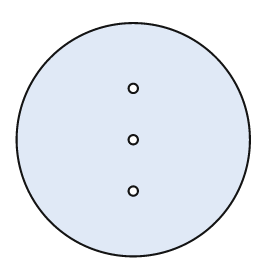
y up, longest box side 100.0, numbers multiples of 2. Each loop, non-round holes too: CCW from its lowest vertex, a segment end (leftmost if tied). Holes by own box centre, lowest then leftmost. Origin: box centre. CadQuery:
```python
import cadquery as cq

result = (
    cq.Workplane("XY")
    .moveTo(0.0, 0.0)
    .circle(50.0)
    .moveTo(0.0, -22.0)
    .circle(2.0)
    .moveTo(0.0, 0.0)
    .circle(2.0)
    .moveTo(0.0, 22.0)
    .circle(2.0)
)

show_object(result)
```